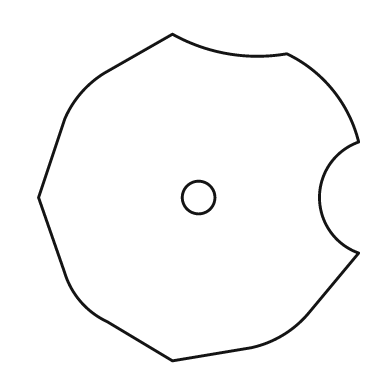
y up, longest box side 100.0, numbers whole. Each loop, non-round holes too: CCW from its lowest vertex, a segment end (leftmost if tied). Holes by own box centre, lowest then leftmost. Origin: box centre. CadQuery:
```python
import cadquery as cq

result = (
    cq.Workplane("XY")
    .moveTo(-8.0, -50.0)
    .lineTo(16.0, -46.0)
    .threePointArc((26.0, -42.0), (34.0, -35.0))
    .lineTo(49.0, -17.0)
    .threePointArc((37.0, 0.0), (49.0, 17.0))
    .threePointArc((41.0, 33.0), (27.0, 44.0))
    .threePointArc((9.0, 44.0), (-8.0, 50.0))
    .lineTo(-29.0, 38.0)
    .threePointArc((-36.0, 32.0), (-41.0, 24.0))
    .lineTo(-49.0, 0.0)
    .lineTo(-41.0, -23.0)
    .threePointArc((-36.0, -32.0), (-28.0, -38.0))
    .close()
    .moveTo(0.0, 0.0)
    .circle(5.0)
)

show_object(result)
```